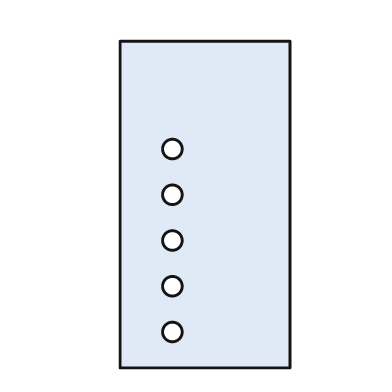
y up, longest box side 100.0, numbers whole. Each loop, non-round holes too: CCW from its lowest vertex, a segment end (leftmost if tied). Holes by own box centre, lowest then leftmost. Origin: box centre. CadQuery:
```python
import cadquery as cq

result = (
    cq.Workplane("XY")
    .moveTo(-26.0, -50.0)
    .lineTo(26.0, -50.0)
    .lineTo(26.0, 50.0)
    .lineTo(-26.0, 50.0)
    .close()
    .moveTo(-10.0, -39.0)
    .circle(3.0)
    .moveTo(-10.0, -25.0)
    .circle(3.0)
    .moveTo(-10.0, -11.0)
    .circle(3.0)
    .moveTo(-10.0, 3.0)
    .circle(3.0)
    .moveTo(-10.0, 17.0)
    .circle(3.0)
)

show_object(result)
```